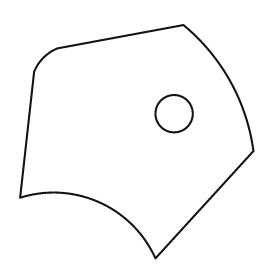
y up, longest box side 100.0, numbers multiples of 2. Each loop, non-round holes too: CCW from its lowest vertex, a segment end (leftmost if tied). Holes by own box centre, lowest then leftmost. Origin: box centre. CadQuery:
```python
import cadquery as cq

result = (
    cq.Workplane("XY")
    .moveTo(8.0, -50.0)
    .lineTo(50.0, -4.0)
    .threePointArc((40.0, 26.0), (20.0, 50.0))
    .lineTo(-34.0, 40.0)
    .threePointArc((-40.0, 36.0), (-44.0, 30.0))
    .lineTo(-50.0, -24.0)
    .threePointArc((-16.0, -26.0), (8.0, -50.0))
    .close()
    .moveTo(16.0, 12.0)
    .circle(8.0)
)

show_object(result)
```